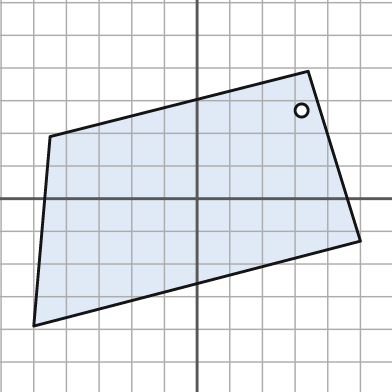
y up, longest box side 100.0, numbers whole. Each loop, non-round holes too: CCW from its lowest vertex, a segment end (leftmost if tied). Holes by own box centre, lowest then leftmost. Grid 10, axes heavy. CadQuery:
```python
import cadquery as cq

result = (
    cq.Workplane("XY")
    .moveTo(-50.0, -39.0)
    .lineTo(50.0, -13.0)
    .lineTo(34.0, 39.0)
    .lineTo(-45.0, 19.0)
    .close()
    .moveTo(32.0, 27.0)
    .circle(2.0)
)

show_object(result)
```